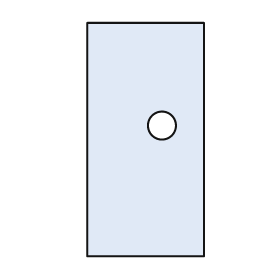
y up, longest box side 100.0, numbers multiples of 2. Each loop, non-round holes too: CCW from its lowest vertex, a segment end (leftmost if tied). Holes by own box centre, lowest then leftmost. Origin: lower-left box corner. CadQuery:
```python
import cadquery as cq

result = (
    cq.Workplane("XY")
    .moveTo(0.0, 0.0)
    .lineTo(50.0, 0.0)
    .lineTo(50.0, 100.0)
    .lineTo(0.0, 100.0)
    .close()
    .moveTo(32.0, 56.0)
    .circle(6.0)
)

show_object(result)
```